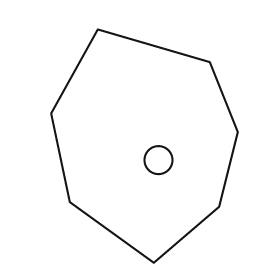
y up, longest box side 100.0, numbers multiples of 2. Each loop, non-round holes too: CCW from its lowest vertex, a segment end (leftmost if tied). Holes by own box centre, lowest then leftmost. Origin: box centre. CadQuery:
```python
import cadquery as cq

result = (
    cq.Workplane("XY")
    .moveTo(4.0, -50.0)
    .lineTo(32.0, -26.0)
    .lineTo(40.0, 6.0)
    .lineTo(28.0, 36.0)
    .lineTo(-20.0, 50.0)
    .lineTo(-40.0, 14.0)
    .lineTo(-32.0, -24.0)
    .close()
    .moveTo(6.0, -6.0)
    .circle(6.0)
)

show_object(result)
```